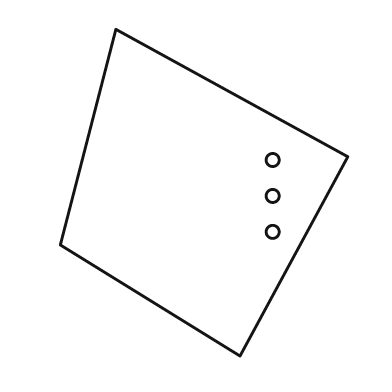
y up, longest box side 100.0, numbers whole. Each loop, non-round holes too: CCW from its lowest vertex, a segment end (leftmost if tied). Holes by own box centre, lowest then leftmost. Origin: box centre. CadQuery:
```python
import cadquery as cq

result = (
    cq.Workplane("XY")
    .moveTo(11.0, -50.0)
    .lineTo(44.0, 11.0)
    .lineTo(-27.0, 50.0)
    .lineTo(-44.0, -16.0)
    .close()
    .moveTo(21.0, -12.0)
    .circle(2.0)
    .moveTo(21.0, -1.0)
    .circle(2.0)
    .moveTo(21.0, 10.0)
    .circle(2.0)
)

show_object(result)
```